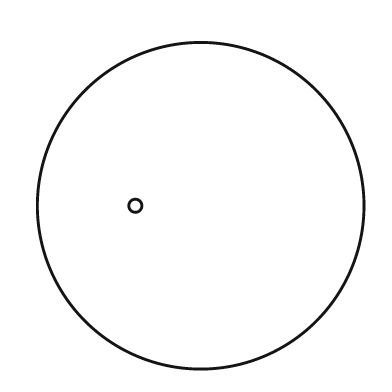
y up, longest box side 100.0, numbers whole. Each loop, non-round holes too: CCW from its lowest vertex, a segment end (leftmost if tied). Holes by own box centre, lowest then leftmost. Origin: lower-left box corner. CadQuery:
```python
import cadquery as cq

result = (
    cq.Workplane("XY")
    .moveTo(50.0, 50.0)
    .circle(50.0)
    .moveTo(30.0, 50.0)
    .circle(2.0)
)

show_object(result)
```